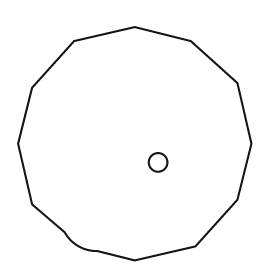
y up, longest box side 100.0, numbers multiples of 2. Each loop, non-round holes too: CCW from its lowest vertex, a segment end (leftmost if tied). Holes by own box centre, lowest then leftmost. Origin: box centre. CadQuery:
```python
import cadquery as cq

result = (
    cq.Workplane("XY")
    .moveTo(0.0, -50.0)
    .lineTo(26.0, -44.0)
    .lineTo(44.0, -24.0)
    .lineTo(50.0, 0.0)
    .lineTo(44.0, 26.0)
    .lineTo(24.0, 44.0)
    .lineTo(0.0, 50.0)
    .lineTo(-26.0, 44.0)
    .lineTo(-44.0, 24.0)
    .lineTo(-50.0, 0.0)
    .lineTo(-44.0, -26.0)
    .lineTo(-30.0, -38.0)
    .threePointArc((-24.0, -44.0), (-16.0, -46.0))
    .close()
    .moveTo(10.0, -8.0)
    .circle(4.0)
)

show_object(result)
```